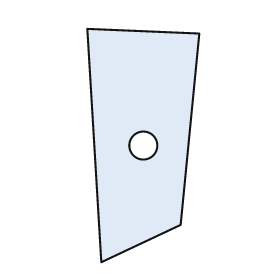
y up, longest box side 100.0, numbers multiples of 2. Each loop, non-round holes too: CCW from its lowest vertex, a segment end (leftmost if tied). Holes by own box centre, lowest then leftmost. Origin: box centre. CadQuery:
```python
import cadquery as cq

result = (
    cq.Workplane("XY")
    .moveTo(-18.0, -50.0)
    .lineTo(16.0, -34.0)
    .lineTo(24.0, 48.0)
    .lineTo(-24.0, 50.0)
    .close()
    .moveTo(0.0, 0.0)
    .circle(6.0)
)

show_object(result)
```